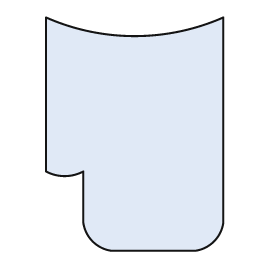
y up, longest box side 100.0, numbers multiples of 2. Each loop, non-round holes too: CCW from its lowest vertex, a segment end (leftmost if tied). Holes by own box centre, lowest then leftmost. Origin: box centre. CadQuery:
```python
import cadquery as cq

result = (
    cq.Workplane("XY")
    .moveTo(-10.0, -50.0)
    .lineTo(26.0, -50.0)
    .threePointArc((34.0, -46.0), (38.0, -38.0))
    .lineTo(38.0, 50.0)
    .threePointArc((0.0, 42.0), (-38.0, 50.0))
    .lineTo(-38.0, -16.0)
    .threePointArc((-30.0, -18.0), (-22.0, -16.0))
    .lineTo(-22.0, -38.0)
    .threePointArc((-18.0, -46.0), (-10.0, -50.0))
    .close()
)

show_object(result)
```